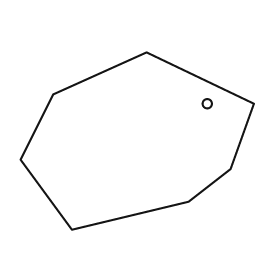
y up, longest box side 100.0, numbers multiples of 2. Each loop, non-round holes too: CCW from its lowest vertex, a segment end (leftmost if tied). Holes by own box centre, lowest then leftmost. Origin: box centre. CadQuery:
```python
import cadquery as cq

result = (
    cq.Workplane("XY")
    .moveTo(-28.0, -38.0)
    .lineTo(22.0, -26.0)
    .lineTo(40.0, -12.0)
    .lineTo(50.0, 16.0)
    .lineTo(4.0, 38.0)
    .lineTo(-36.0, 20.0)
    .lineTo(-50.0, -8.0)
    .close()
    .moveTo(30.0, 16.0)
    .circle(2.0)
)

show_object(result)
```